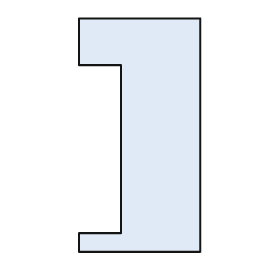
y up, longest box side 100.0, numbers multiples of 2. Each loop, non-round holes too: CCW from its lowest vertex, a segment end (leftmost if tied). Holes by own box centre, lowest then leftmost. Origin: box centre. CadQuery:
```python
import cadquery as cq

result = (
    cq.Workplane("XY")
    .moveTo(-26.0, -50.0)
    .lineTo(26.0, -50.0)
    .lineTo(26.0, 50.0)
    .lineTo(-26.0, 50.0)
    .lineTo(-26.0, 30.0)
    .lineTo(-8.0, 30.0)
    .lineTo(-8.0, -42.0)
    .lineTo(-26.0, -42.0)
    .close()
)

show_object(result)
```